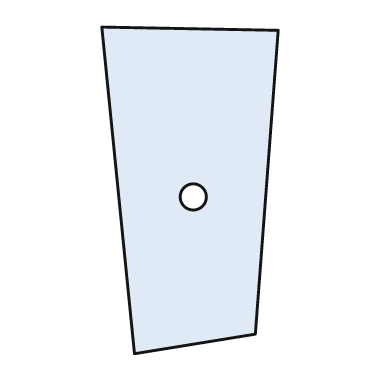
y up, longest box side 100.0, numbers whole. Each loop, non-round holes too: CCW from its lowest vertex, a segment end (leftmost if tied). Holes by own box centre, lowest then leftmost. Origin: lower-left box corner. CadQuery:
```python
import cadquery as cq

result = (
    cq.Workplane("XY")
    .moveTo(10.0, 0.0)
    .lineTo(47.0, 6.0)
    .lineTo(54.0, 99.0)
    .lineTo(0.0, 100.0)
    .close()
    .moveTo(28.0, 48.0)
    .circle(4.0)
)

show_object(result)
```